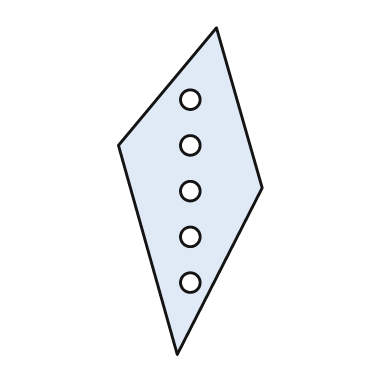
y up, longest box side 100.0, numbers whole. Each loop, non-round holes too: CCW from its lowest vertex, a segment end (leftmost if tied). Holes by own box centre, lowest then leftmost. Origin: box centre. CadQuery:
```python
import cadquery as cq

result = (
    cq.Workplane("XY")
    .moveTo(-4.0, -50.0)
    .lineTo(22.0, 1.0)
    .lineTo(8.0, 50.0)
    .lineTo(-22.0, 14.0)
    .close()
    .moveTo(0.0, -28.0)
    .circle(3.0)
    .moveTo(0.0, -14.0)
    .circle(3.0)
    .moveTo(0.0, 0.0)
    .circle(3.0)
    .moveTo(0.0, 14.0)
    .circle(3.0)
    .moveTo(0.0, 28.0)
    .circle(3.0)
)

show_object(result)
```